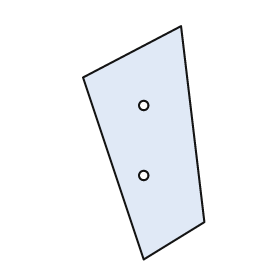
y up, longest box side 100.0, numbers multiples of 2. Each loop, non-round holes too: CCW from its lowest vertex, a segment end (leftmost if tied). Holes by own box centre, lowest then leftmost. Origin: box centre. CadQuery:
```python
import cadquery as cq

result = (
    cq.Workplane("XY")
    .moveTo(0.0, -50.0)
    .lineTo(26.0, -34.0)
    .lineTo(16.0, 50.0)
    .lineTo(-26.0, 28.0)
    .close()
    .moveTo(0.0, -14.0)
    .circle(2.0)
    .moveTo(0.0, 16.0)
    .circle(2.0)
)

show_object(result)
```